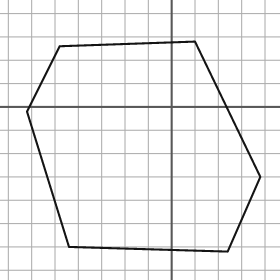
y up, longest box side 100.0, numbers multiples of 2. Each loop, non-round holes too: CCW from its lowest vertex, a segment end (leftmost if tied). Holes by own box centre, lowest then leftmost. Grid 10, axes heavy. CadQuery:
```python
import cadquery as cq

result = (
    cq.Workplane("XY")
    .moveTo(24.0, -62.0)
    .lineTo(38.0, -30.0)
    .lineTo(10.0, 28.0)
    .lineTo(-48.0, 26.0)
    .lineTo(-62.0, -2.0)
    .lineTo(-44.0, -60.0)
    .close()
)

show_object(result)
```